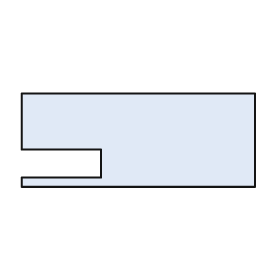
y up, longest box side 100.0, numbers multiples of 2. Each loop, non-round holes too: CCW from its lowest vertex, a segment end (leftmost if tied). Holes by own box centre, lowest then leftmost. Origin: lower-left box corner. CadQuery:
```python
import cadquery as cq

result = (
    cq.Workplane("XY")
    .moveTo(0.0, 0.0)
    .lineTo(100.0, 0.0)
    .lineTo(100.0, 40.0)
    .lineTo(0.0, 40.0)
    .lineTo(0.0, 16.0)
    .lineTo(34.0, 16.0)
    .lineTo(34.0, 4.0)
    .lineTo(0.0, 4.0)
    .close()
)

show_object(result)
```